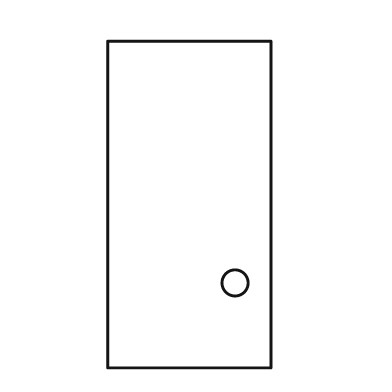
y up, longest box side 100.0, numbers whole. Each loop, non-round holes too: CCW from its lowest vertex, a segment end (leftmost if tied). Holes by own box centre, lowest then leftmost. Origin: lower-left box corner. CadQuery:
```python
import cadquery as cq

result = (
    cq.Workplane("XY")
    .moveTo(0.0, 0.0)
    .lineTo(50.0, 0.0)
    .lineTo(50.0, 100.0)
    .lineTo(0.0, 100.0)
    .close()
    .moveTo(39.0, 26.0)
    .circle(4.0)
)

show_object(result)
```